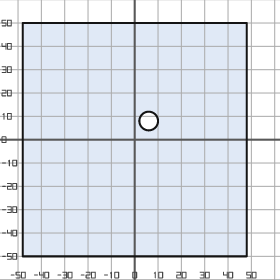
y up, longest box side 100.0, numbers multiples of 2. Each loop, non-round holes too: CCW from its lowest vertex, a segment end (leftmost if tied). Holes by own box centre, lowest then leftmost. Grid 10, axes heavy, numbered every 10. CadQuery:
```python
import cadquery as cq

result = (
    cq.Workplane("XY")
    .moveTo(-48.0, -50.0)
    .lineTo(48.0, -50.0)
    .lineTo(48.0, 50.0)
    .lineTo(-48.0, 50.0)
    .close()
    .moveTo(6.0, 8.0)
    .circle(4.0)
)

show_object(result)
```